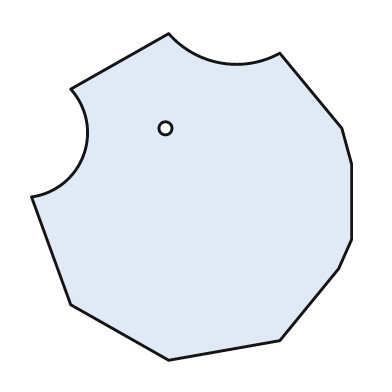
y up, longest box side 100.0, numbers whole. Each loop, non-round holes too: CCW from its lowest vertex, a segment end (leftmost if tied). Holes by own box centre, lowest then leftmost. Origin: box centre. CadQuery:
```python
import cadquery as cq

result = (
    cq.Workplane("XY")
    .moveTo(-7.0, -50.0)
    .lineTo(27.0, -44.0)
    .lineTo(45.0, -22.0)
    .lineTo(49.0, -13.0)
    .lineTo(49.0, 10.0)
    .lineTo(46.0, 21.0)
    .lineTo(27.0, 44.0)
    .threePointArc((9.0, 41.0), (-7.0, 50.0))
    .lineTo(-37.0, 33.0)
    .threePointArc((-33.0, 13.0), (-49.0, 0.0))
    .lineTo(-37.0, -33.0)
    .close()
    .moveTo(-8.0, 21.0)
    .circle(2.0)
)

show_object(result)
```